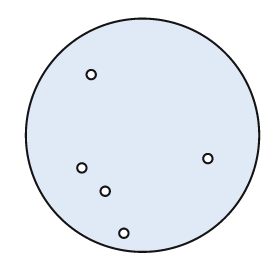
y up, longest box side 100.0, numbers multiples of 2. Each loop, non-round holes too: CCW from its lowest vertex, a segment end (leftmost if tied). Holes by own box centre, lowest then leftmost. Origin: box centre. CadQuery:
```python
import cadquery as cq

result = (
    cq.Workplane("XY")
    .moveTo(0.0, 0.0)
    .circle(50.0)
    .moveTo(-8.0, -42.0)
    .circle(2.0)
    .moveTo(-16.0, -24.0)
    .circle(2.0)
    .moveTo(-26.0, -14.0)
    .circle(2.0)
    .moveTo(28.0, -10.0)
    .circle(2.0)
    .moveTo(-22.0, 26.0)
    .circle(2.0)
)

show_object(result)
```